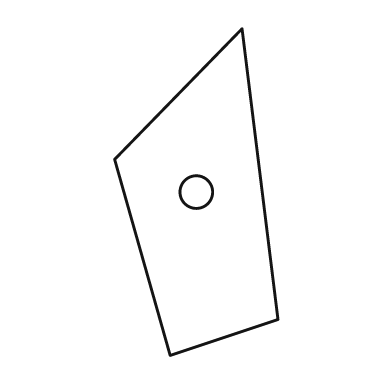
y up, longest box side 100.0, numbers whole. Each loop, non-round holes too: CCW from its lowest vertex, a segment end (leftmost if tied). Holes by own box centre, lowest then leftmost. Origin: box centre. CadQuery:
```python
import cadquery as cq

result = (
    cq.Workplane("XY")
    .moveTo(-8.0, -50.0)
    .lineTo(25.0, -39.0)
    .lineTo(14.0, 50.0)
    .lineTo(-25.0, 10.0)
    .close()
    .moveTo(0.0, 0.0)
    .circle(5.0)
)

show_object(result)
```